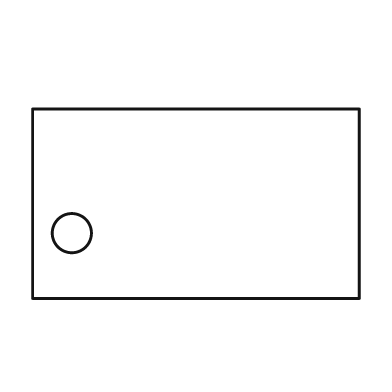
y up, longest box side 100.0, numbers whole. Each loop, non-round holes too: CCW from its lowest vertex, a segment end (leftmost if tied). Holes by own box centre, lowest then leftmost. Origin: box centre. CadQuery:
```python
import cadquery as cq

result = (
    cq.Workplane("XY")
    .moveTo(-50.0, -29.0)
    .lineTo(50.0, -29.0)
    .lineTo(50.0, 29.0)
    .lineTo(-50.0, 29.0)
    .close()
    .moveTo(-38.0, -9.0)
    .circle(6.0)
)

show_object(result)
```